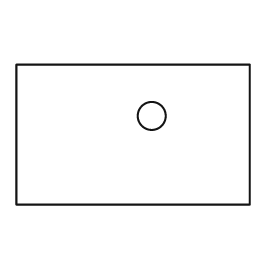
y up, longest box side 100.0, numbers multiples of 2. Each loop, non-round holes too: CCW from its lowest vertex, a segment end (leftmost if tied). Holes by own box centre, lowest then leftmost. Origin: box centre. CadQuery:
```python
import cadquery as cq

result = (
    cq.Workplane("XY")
    .moveTo(-50.0, -30.0)
    .lineTo(50.0, -30.0)
    .lineTo(50.0, 30.0)
    .lineTo(-50.0, 30.0)
    .close()
    .moveTo(8.0, 8.0)
    .circle(6.0)
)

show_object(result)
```